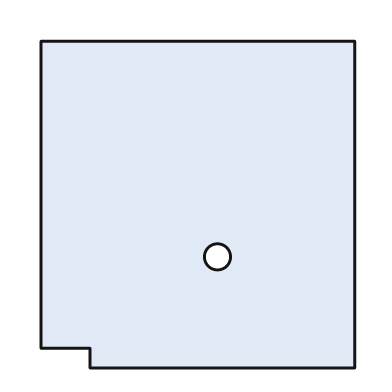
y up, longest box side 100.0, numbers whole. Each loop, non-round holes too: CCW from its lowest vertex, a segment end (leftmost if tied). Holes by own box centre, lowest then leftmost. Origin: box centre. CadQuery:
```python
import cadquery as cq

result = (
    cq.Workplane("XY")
    .moveTo(-33.0, -50.0)
    .lineTo(48.0, -50.0)
    .lineTo(48.0, 50.0)
    .lineTo(-48.0, 50.0)
    .lineTo(-48.0, -44.0)
    .lineTo(-33.0, -44.0)
    .close()
    .moveTo(6.0, -16.0)
    .circle(4.0)
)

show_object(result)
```